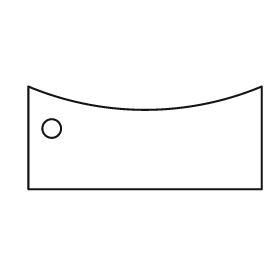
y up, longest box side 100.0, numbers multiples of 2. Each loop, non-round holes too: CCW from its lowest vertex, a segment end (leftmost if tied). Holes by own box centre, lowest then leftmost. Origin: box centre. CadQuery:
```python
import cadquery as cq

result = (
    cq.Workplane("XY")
    .moveTo(-50.0, -22.0)
    .lineTo(50.0, -22.0)
    .lineTo(50.0, 22.0)
    .threePointArc((0.0, 12.0), (-50.0, 22.0))
    .close()
    .moveTo(-40.0, 4.0)
    .circle(4.0)
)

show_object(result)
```